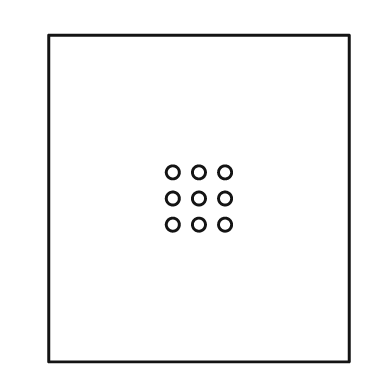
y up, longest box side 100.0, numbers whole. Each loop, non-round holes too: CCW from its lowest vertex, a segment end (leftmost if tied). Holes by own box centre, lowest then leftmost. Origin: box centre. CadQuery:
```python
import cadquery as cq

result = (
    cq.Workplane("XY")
    .moveTo(-46.0, -50.0)
    .lineTo(46.0, -50.0)
    .lineTo(46.0, 50.0)
    .lineTo(-46.0, 50.0)
    .close()
    .moveTo(-8.0, -8.0)
    .circle(2.0)
    .moveTo(0.0, -8.0)
    .circle(2.0)
    .moveTo(8.0, -8.0)
    .circle(2.0)
    .moveTo(-8.0, 0.0)
    .circle(2.0)
    .moveTo(0.0, 0.0)
    .circle(2.0)
    .moveTo(8.0, 0.0)
    .circle(2.0)
    .moveTo(-8.0, 8.0)
    .circle(2.0)
    .moveTo(0.0, 8.0)
    .circle(2.0)
    .moveTo(8.0, 8.0)
    .circle(2.0)
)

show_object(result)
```